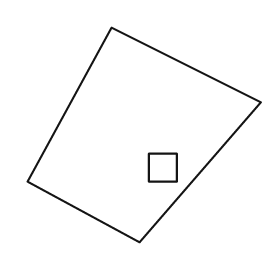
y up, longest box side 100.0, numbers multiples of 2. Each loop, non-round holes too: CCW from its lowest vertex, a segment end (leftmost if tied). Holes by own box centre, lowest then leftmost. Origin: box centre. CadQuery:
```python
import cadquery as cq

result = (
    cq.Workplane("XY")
    .moveTo(-2.0, -46.0)
    .lineTo(50.0, 14.0)
    .lineTo(-14.0, 46.0)
    .lineTo(-50.0, -20.0)
    .close()
    .moveTo(2.0, -20.0)
    .lineTo(14.0, -20.0)
    .lineTo(14.0, -8.0)
    .lineTo(2.0, -8.0)
    .close()
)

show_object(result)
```